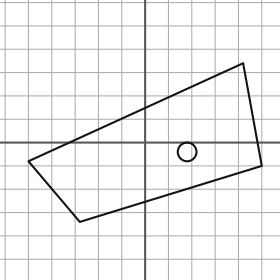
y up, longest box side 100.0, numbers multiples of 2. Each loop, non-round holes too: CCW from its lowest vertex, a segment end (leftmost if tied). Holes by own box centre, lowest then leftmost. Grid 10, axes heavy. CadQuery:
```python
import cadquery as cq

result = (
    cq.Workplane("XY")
    .moveTo(-28.0, -34.0)
    .lineTo(50.0, -10.0)
    .lineTo(42.0, 34.0)
    .lineTo(-50.0, -8.0)
    .close()
    .moveTo(18.0, -4.0)
    .circle(4.0)
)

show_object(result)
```